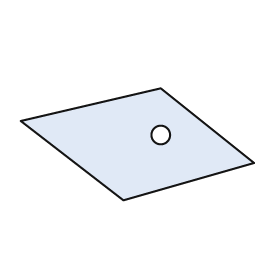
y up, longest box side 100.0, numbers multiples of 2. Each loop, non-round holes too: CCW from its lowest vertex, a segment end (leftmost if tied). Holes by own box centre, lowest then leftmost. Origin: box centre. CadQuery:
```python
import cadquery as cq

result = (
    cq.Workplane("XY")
    .moveTo(-6.0, -24.0)
    .lineTo(50.0, -8.0)
    .lineTo(10.0, 24.0)
    .lineTo(-50.0, 10.0)
    .close()
    .moveTo(10.0, 4.0)
    .circle(4.0)
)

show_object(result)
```